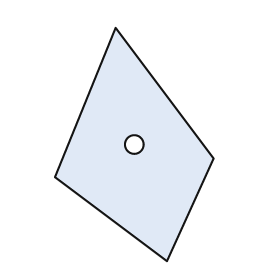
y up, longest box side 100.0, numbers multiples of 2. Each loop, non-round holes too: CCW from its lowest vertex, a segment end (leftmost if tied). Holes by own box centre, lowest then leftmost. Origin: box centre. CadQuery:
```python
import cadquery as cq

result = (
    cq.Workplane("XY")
    .moveTo(14.0, -50.0)
    .lineTo(34.0, -6.0)
    .lineTo(-8.0, 50.0)
    .lineTo(-34.0, -14.0)
    .close()
    .moveTo(0.0, 0.0)
    .circle(4.0)
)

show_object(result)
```